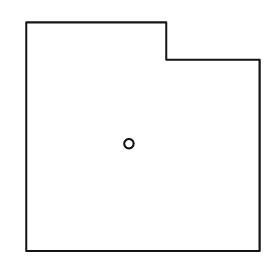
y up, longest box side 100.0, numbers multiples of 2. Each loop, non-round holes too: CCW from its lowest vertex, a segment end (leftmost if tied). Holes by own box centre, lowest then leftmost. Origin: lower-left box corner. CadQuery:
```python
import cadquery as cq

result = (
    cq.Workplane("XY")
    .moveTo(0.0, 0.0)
    .lineTo(100.0, 0.0)
    .lineTo(100.0, 82.0)
    .lineTo(60.0, 82.0)
    .lineTo(60.0, 98.0)
    .lineTo(0.0, 98.0)
    .close()
    .moveTo(44.0, 46.0)
    .circle(2.0)
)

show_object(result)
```